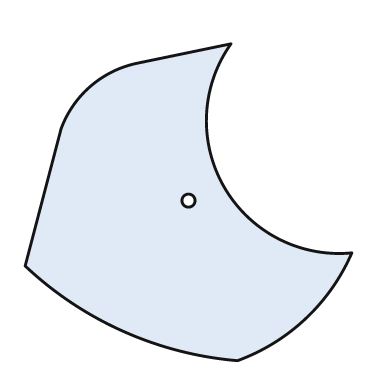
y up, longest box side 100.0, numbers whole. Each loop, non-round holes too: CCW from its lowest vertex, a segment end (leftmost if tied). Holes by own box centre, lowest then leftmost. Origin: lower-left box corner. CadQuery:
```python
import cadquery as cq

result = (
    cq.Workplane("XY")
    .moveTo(65.0, 0.0)
    .threePointArc((86.0, 13.0), (100.0, 33.0))
    .threePointArc((61.0, 53.0), (63.0, 97.0))
    .lineTo(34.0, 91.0)
    .threePointArc((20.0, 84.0), (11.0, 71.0))
    .lineTo(0.0, 29.0)
    .threePointArc((30.0, 9.0), (65.0, 0.0))
    .close()
    .moveTo(50.0, 49.0)
    .circle(2.0)
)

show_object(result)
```